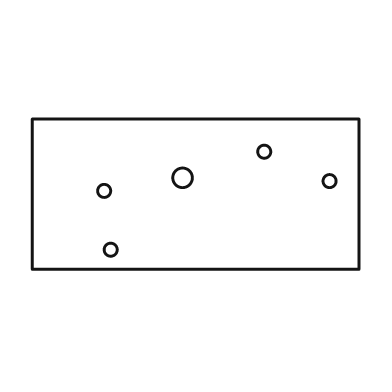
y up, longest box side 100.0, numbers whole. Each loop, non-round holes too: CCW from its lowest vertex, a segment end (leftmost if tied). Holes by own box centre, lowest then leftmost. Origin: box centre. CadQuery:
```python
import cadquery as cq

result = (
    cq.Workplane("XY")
    .moveTo(-50.0, -23.0)
    .lineTo(50.0, -23.0)
    .lineTo(50.0, 23.0)
    .lineTo(-50.0, 23.0)
    .close()
    .moveTo(-26.0, -17.0)
    .circle(2.0)
    .moveTo(-28.0, 1.0)
    .circle(2.0)
    .moveTo(41.0, 4.0)
    .circle(2.0)
    .moveTo(-4.0, 5.0)
    .circle(3.0)
    .moveTo(21.0, 13.0)
    .circle(2.0)
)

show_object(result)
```